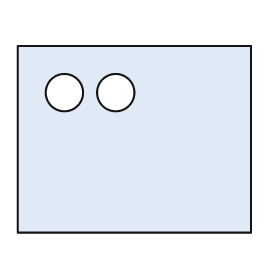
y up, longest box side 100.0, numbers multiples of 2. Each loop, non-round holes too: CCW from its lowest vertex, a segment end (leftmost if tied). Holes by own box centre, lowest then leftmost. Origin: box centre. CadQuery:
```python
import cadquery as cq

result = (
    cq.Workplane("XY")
    .moveTo(-50.0, -40.0)
    .lineTo(50.0, -40.0)
    .lineTo(50.0, 40.0)
    .lineTo(-50.0, 40.0)
    .close()
    .moveTo(-30.0, 20.0)
    .circle(8.0)
    .moveTo(-8.0, 20.0)
    .circle(8.0)
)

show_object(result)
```